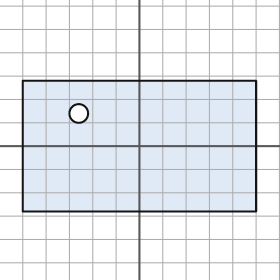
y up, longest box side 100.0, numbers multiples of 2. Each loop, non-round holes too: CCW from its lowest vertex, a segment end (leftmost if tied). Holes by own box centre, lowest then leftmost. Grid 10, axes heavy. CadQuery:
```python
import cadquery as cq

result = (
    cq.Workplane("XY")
    .moveTo(-50.0, -28.0)
    .lineTo(50.0, -28.0)
    .lineTo(50.0, 28.0)
    .lineTo(-50.0, 28.0)
    .close()
    .moveTo(-26.0, 14.0)
    .circle(4.0)
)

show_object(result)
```